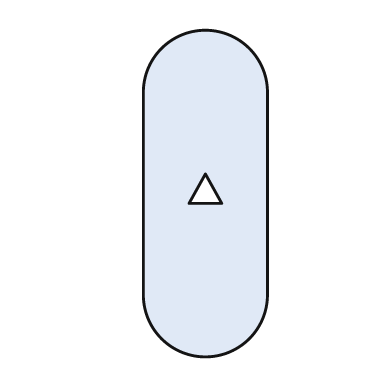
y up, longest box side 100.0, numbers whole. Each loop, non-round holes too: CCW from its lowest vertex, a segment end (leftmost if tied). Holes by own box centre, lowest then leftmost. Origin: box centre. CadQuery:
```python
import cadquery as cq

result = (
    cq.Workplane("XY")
    .moveTo(-19.0, -31.0)
    .threePointArc((0.0, -50.0), (19.0, -31.0))
    .lineTo(19.0, 31.0)
    .threePointArc((0.0, 50.0), (-19.0, 31.0))
    .close()
    .moveTo(-5.0, -3.0)
    .lineTo(5.0, -3.0)
    .lineTo(0.0, 6.0)
    .close()
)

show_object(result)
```